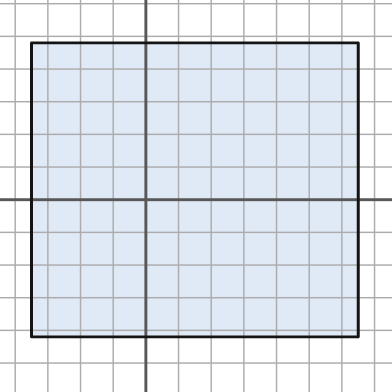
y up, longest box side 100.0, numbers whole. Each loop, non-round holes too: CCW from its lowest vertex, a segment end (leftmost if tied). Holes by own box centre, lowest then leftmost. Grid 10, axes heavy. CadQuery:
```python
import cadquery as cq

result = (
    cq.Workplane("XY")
    .moveTo(-35.0, -42.0)
    .lineTo(65.0, -42.0)
    .lineTo(65.0, 48.0)
    .lineTo(-35.0, 48.0)
    .close()
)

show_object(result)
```